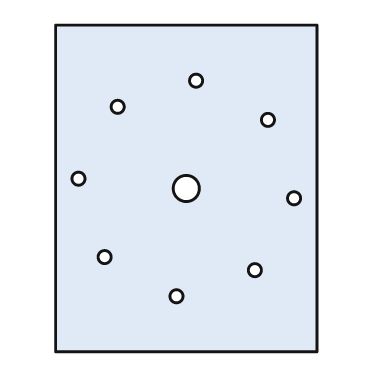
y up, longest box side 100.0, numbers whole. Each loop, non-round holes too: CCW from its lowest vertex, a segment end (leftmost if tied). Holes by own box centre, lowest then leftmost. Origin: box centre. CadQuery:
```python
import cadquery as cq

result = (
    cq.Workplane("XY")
    .moveTo(-40.0, -50.0)
    .lineTo(40.0, -50.0)
    .lineTo(40.0, 50.0)
    .lineTo(-40.0, 50.0)
    .close()
    .moveTo(-3.0, -33.0)
    .circle(2.0)
    .moveTo(21.0, -25.0)
    .circle(2.0)
    .moveTo(-25.0, -21.0)
    .circle(2.0)
    .moveTo(33.0, -3.0)
    .circle(2.0)
    .moveTo(0.0, 0.0)
    .circle(4.0)
    .moveTo(-33.0, 3.0)
    .circle(2.0)
    .moveTo(25.0, 21.0)
    .circle(2.0)
    .moveTo(-21.0, 25.0)
    .circle(2.0)
    .moveTo(3.0, 33.0)
    .circle(2.0)
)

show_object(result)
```